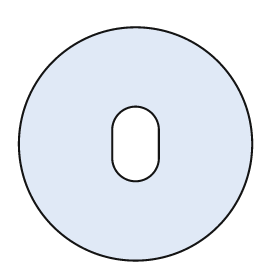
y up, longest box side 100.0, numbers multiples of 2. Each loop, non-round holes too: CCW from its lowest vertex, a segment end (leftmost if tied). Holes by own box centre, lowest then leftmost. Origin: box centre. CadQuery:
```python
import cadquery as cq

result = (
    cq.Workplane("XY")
    .moveTo(0.0, 0.0)
    .circle(50.0)
    .moveTo(-10.0, -6.0)
    .threePointArc((0.0, -16.0), (10.0, -6.0))
    .lineTo(10.0, 6.0)
    .threePointArc((0.0, 16.0), (-10.0, 6.0))
    .close()
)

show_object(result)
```